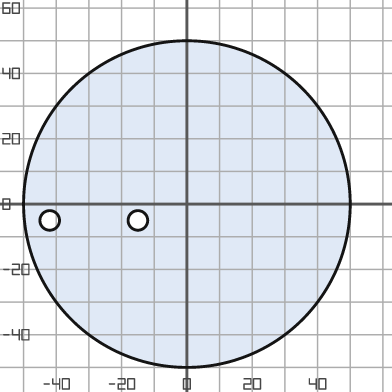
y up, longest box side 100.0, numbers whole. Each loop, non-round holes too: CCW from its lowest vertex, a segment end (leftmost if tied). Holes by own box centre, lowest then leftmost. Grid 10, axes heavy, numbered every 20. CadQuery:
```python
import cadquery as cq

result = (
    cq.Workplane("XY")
    .moveTo(0.0, 0.0)
    .circle(50.0)
    .moveTo(-42.0, -5.0)
    .circle(3.0)
    .moveTo(-15.0, -5.0)
    .circle(3.0)
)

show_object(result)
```